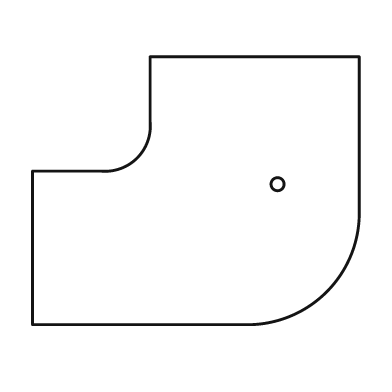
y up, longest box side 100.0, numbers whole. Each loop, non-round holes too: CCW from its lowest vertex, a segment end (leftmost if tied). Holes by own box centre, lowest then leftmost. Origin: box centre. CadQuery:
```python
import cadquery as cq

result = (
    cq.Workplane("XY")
    .moveTo(-50.0, -41.0)
    .lineTo(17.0, -41.0)
    .threePointArc((40.0, -31.0), (50.0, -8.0))
    .lineTo(50.0, 41.0)
    .lineTo(-14.0, 41.0)
    .lineTo(-14.0, 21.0)
    .threePointArc((-18.0, 10.0), (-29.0, 6.0))
    .lineTo(-50.0, 6.0)
    .close()
    .moveTo(25.0, 2.0)
    .circle(2.0)
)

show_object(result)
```